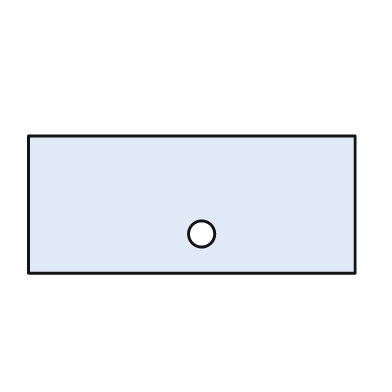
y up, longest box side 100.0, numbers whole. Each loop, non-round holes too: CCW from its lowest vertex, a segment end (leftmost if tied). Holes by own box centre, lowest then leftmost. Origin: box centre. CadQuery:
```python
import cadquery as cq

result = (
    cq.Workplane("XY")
    .moveTo(-50.0, -21.0)
    .lineTo(50.0, -21.0)
    .lineTo(50.0, 21.0)
    .lineTo(-50.0, 21.0)
    .close()
    .moveTo(3.0, -9.0)
    .circle(4.0)
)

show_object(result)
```